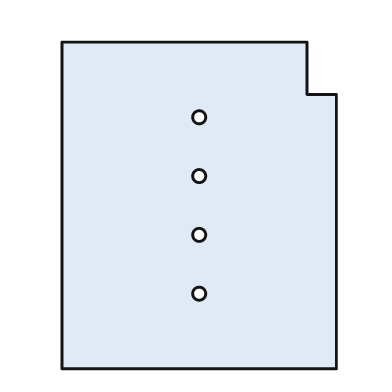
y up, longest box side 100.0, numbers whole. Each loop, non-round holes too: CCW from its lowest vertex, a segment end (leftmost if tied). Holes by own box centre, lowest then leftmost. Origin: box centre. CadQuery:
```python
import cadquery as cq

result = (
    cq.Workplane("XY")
    .moveTo(-42.0, -50.0)
    .lineTo(42.0, -50.0)
    .lineTo(42.0, 34.0)
    .lineTo(33.0, 34.0)
    .lineTo(33.0, 50.0)
    .lineTo(-42.0, 50.0)
    .close()
    .moveTo(0.0, -27.0)
    .circle(2.0)
    .moveTo(0.0, -9.0)
    .circle(2.0)
    .moveTo(0.0, 9.0)
    .circle(2.0)
    .moveTo(0.0, 27.0)
    .circle(2.0)
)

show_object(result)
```